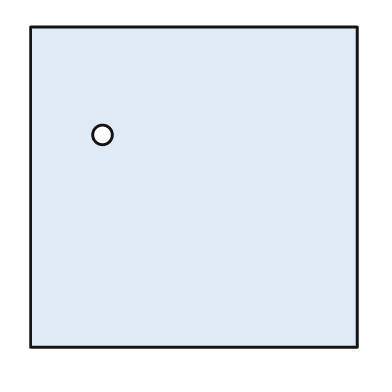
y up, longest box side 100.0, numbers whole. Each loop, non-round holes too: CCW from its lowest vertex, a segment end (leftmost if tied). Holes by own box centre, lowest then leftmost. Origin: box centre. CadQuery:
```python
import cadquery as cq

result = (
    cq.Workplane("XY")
    .moveTo(-50.0, -49.0)
    .lineTo(50.0, -49.0)
    .lineTo(50.0, 49.0)
    .lineTo(-50.0, 49.0)
    .close()
    .moveTo(-28.0, 16.0)
    .circle(3.0)
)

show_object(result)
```